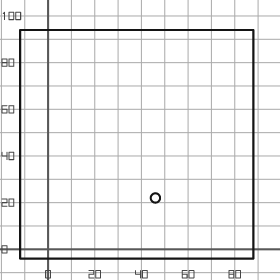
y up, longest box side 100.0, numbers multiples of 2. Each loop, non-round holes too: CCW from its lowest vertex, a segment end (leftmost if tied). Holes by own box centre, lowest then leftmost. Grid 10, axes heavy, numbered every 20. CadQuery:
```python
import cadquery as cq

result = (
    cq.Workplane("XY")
    .moveTo(-12.0, -4.0)
    .lineTo(88.0, -4.0)
    .lineTo(88.0, 94.0)
    .lineTo(-12.0, 94.0)
    .close()
    .moveTo(46.0, 22.0)
    .circle(2.0)
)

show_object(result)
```